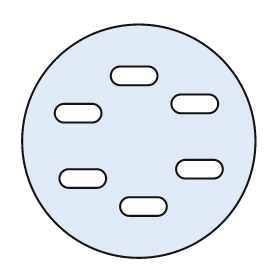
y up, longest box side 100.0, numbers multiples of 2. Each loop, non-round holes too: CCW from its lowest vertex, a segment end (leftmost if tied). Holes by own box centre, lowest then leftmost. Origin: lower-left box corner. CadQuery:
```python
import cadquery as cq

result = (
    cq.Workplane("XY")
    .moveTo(50.0, 50.0)
    .circle(50.0)
    .moveTo(46.0, 18.0)
    .lineTo(58.0, 18.0)
    .threePointArc((62.0, 22.0), (58.0, 26.0))
    .lineTo(46.0, 26.0)
    .threePointArc((42.0, 22.0), (46.0, 18.0))
    .close()
    .moveTo(20.0, 30.0)
    .lineTo(32.0, 30.0)
    .threePointArc((36.0, 34.0), (32.0, 38.0))
    .lineTo(20.0, 38.0)
    .threePointArc((16.0, 34.0), (20.0, 30.0))
    .close()
    .moveTo(70.0, 34.0)
    .lineTo(82.0, 34.0)
    .threePointArc((86.0, 38.0), (82.0, 42.0))
    .lineTo(70.0, 42.0)
    .threePointArc((66.0, 38.0), (70.0, 34.0))
    .close()
    .moveTo(18.0, 58.0)
    .lineTo(30.0, 58.0)
    .threePointArc((34.0, 62.0), (30.0, 66.0))
    .lineTo(18.0, 66.0)
    .threePointArc((14.0, 62.0), (18.0, 58.0))
    .close()
    .moveTo(68.0, 62.0)
    .lineTo(80.0, 62.0)
    .threePointArc((84.0, 66.0), (80.0, 70.0))
    .lineTo(68.0, 70.0)
    .threePointArc((64.0, 66.0), (68.0, 62.0))
    .close()
    .moveTo(42.0, 74.0)
    .lineTo(54.0, 74.0)
    .threePointArc((58.0, 78.0), (54.0, 82.0))
    .lineTo(42.0, 82.0)
    .threePointArc((38.0, 78.0), (42.0, 74.0))
    .close()
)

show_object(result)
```